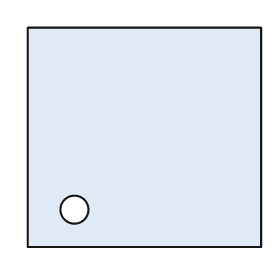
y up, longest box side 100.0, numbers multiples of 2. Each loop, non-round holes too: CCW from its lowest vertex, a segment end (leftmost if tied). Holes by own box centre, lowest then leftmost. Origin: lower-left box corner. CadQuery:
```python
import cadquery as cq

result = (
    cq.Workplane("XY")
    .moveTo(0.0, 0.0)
    .lineTo(100.0, 0.0)
    .lineTo(100.0, 94.0)
    .lineTo(0.0, 94.0)
    .close()
    .moveTo(20.0, 16.0)
    .circle(6.0)
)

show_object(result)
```